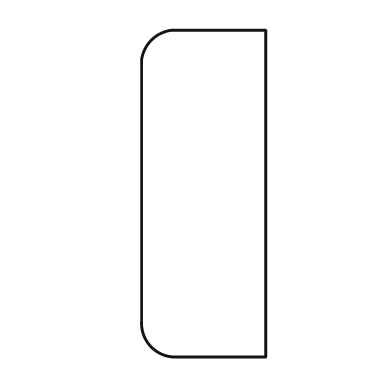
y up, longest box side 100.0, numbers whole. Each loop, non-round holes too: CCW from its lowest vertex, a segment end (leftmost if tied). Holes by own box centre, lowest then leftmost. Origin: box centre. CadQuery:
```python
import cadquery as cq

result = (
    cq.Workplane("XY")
    .moveTo(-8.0, -50.0)
    .lineTo(19.0, -50.0)
    .lineTo(19.0, 50.0)
    .lineTo(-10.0, 50.0)
    .threePointArc((-16.0, 47.0), (-19.0, 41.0))
    .lineTo(-19.0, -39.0)
    .threePointArc((-16.0, -47.0), (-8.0, -50.0))
    .close()
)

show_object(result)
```